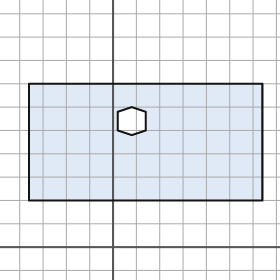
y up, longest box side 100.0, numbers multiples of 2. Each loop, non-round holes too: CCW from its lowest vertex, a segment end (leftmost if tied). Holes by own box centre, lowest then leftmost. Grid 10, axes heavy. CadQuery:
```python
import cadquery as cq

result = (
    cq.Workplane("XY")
    .moveTo(-36.0, 20.0)
    .lineTo(64.0, 20.0)
    .lineTo(64.0, 70.0)
    .lineTo(-36.0, 70.0)
    .close()
    .moveTo(8.0, 48.0)
    .lineTo(14.0, 50.0)
    .lineTo(14.0, 58.0)
    .lineTo(8.0, 60.0)
    .lineTo(2.0, 58.0)
    .lineTo(2.0, 50.0)
    .close()
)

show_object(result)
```